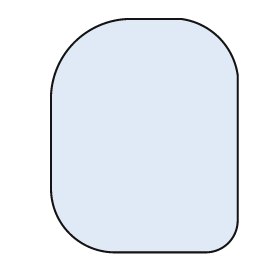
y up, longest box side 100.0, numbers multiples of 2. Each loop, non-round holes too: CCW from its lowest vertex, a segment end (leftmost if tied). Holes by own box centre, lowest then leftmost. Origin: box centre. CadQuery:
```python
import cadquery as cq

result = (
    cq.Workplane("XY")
    .moveTo(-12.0, -50.0)
    .lineTo(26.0, -50.0)
    .threePointArc((36.0, -46.0), (40.0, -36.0))
    .lineTo(40.0, 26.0)
    .threePointArc((32.0, 42.0), (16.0, 50.0))
    .lineTo(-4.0, 50.0)
    .threePointArc((-30.0, 40.0), (-40.0, 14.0))
    .lineTo(-40.0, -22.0)
    .threePointArc((-32.0, -42.0), (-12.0, -50.0))
    .close()
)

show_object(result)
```